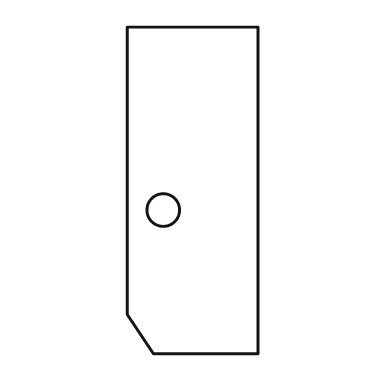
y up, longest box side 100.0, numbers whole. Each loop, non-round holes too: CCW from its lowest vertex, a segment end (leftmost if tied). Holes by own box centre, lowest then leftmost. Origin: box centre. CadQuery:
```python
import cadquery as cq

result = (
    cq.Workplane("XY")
    .moveTo(-12.0, -50.0)
    .lineTo(20.0, -50.0)
    .lineTo(20.0, 50.0)
    .lineTo(-20.0, 50.0)
    .lineTo(-20.0, -38.0)
    .close()
    .moveTo(-9.0, -6.0)
    .circle(5.0)
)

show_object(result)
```